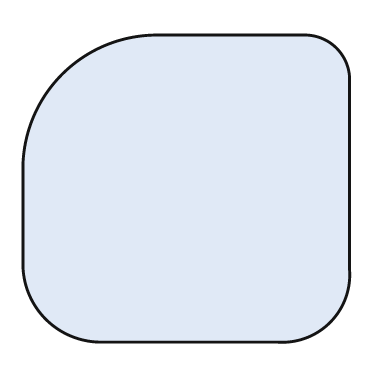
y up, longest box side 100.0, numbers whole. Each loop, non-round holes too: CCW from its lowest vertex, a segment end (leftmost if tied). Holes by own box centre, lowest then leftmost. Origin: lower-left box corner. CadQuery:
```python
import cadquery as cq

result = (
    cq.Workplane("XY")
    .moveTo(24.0, 0.0)
    .lineTo(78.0, 0.0)
    .threePointArc((94.0, 6.0), (100.0, 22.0))
    .lineTo(100.0, 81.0)
    .threePointArc((96.0, 90.0), (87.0, 94.0))
    .lineTo(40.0, 94.0)
    .threePointArc((12.0, 82.0), (0.0, 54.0))
    .lineTo(0.0, 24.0)
    .threePointArc((7.0, 7.0), (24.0, 0.0))
    .close()
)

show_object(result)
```